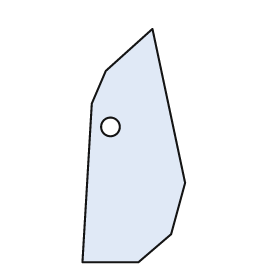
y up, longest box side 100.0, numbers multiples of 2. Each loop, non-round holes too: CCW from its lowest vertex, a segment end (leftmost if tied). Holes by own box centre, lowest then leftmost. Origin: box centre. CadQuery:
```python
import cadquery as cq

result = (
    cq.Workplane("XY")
    .moveTo(-22.0, -50.0)
    .lineTo(2.0, -50.0)
    .lineTo(16.0, -38.0)
    .lineTo(22.0, -16.0)
    .lineTo(8.0, 50.0)
    .lineTo(-12.0, 32.0)
    .lineTo(-18.0, 18.0)
    .close()
    .moveTo(-10.0, 8.0)
    .circle(4.0)
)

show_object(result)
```